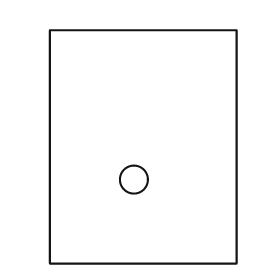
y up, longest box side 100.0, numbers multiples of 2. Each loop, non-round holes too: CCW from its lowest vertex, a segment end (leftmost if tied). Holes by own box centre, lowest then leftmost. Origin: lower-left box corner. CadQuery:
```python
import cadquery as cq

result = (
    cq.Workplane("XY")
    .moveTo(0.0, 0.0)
    .lineTo(80.0, 0.0)
    .lineTo(80.0, 100.0)
    .lineTo(0.0, 100.0)
    .close()
    .moveTo(36.0, 36.0)
    .circle(6.0)
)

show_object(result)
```